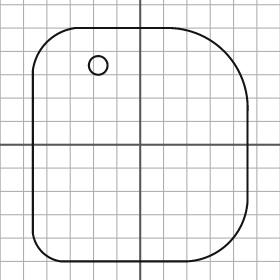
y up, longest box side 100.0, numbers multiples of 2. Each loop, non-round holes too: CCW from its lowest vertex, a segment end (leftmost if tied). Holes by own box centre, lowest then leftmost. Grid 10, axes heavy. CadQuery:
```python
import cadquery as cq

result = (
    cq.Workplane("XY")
    .moveTo(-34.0, -50.0)
    .lineTo(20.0, -50.0)
    .threePointArc((38.0, -42.0), (46.0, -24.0))
    .lineTo(46.0, 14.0)
    .threePointArc((36.0, 40.0), (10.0, 50.0))
    .lineTo(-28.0, 50.0)
    .threePointArc((-40.0, 44.0), (-46.0, 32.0))
    .lineTo(-46.0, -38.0)
    .threePointArc((-42.0, -46.0), (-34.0, -50.0))
    .close()
    .moveTo(-18.0, 34.0)
    .circle(4.0)
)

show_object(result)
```